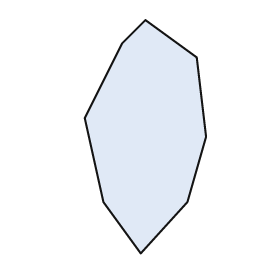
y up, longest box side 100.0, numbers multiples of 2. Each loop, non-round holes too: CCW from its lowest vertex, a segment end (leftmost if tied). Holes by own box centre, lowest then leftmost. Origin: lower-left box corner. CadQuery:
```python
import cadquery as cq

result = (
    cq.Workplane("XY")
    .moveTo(24.0, 0.0)
    .lineTo(44.0, 22.0)
    .lineTo(52.0, 50.0)
    .lineTo(48.0, 84.0)
    .lineTo(26.0, 100.0)
    .lineTo(16.0, 90.0)
    .lineTo(0.0, 58.0)
    .lineTo(8.0, 22.0)
    .close()
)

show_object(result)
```